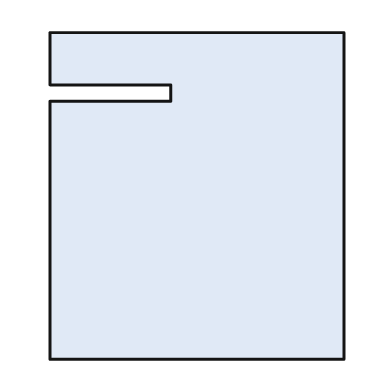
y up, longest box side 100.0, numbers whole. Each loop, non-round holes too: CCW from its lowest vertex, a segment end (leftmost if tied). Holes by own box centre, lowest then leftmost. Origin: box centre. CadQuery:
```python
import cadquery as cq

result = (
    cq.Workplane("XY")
    .moveTo(-45.0, -50.0)
    .lineTo(45.0, -50.0)
    .lineTo(45.0, 50.0)
    .lineTo(-45.0, 50.0)
    .lineTo(-45.0, 34.0)
    .lineTo(-8.0, 34.0)
    .lineTo(-8.0, 29.0)
    .lineTo(-45.0, 29.0)
    .close()
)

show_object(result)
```